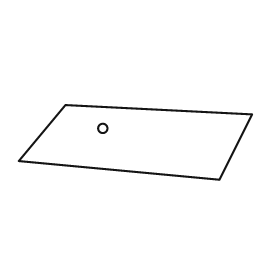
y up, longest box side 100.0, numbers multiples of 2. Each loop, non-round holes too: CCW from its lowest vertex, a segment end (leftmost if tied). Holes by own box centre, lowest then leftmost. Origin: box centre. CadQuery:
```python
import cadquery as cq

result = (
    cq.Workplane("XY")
    .moveTo(36.0, -16.0)
    .lineTo(50.0, 12.0)
    .lineTo(-30.0, 16.0)
    .lineTo(-50.0, -8.0)
    .close()
    .moveTo(-14.0, 6.0)
    .circle(2.0)
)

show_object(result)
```